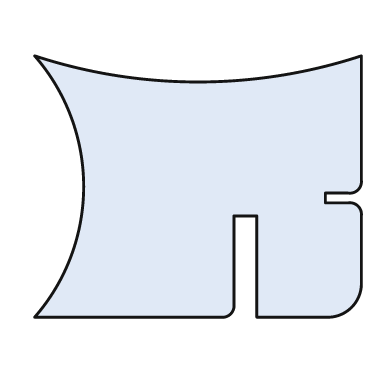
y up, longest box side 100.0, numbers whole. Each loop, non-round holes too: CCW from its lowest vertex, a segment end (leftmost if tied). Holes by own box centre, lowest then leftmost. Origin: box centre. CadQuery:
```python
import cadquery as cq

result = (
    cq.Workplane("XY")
    .moveTo(-50.0, -40.0)
    .lineTo(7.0, -40.0)
    .threePointArc((10.0, -39.0), (11.0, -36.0))
    .lineTo(11.0, -9.0)
    .lineTo(18.0, -9.0)
    .lineTo(18.0, -40.0)
    .lineTo(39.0, -40.0)
    .threePointArc((47.0, -37.0), (50.0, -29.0))
    .lineTo(50.0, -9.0)
    .threePointArc((49.0, -6.0), (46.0, -5.0))
    .lineTo(39.0, -5.0)
    .lineTo(39.0, -2.0)
    .lineTo(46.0, -2.0)
    .threePointArc((49.0, -1.0), (50.0, 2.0))
    .lineTo(50.0, 40.0)
    .threePointArc((0.0, 32.0), (-50.0, 40.0))
    .threePointArc((-35.0, 0.0), (-50.0, -40.0))
    .close()
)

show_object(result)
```